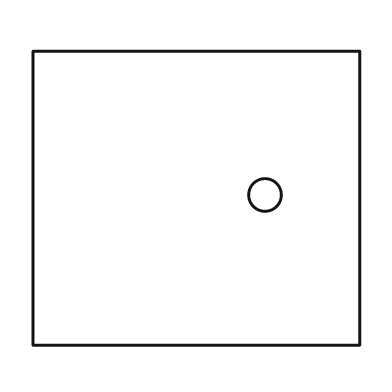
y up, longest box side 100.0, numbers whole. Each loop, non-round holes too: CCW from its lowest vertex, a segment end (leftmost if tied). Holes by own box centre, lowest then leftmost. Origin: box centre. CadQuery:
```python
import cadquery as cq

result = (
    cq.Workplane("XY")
    .moveTo(-50.0, -45.0)
    .lineTo(50.0, -45.0)
    .lineTo(50.0, 45.0)
    .lineTo(-50.0, 45.0)
    .close()
    .moveTo(21.0, 1.0)
    .circle(5.0)
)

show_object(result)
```